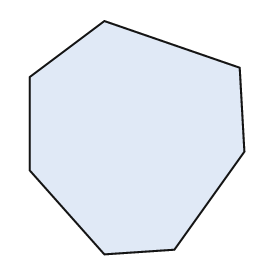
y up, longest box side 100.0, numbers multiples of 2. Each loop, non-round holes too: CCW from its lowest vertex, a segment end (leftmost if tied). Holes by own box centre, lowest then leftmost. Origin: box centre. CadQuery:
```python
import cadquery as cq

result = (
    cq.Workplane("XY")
    .moveTo(-14.0, -50.0)
    .lineTo(16.0, -48.0)
    .lineTo(46.0, -6.0)
    .lineTo(44.0, 30.0)
    .lineTo(-14.0, 50.0)
    .lineTo(-46.0, 26.0)
    .lineTo(-46.0, -14.0)
    .close()
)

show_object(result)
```